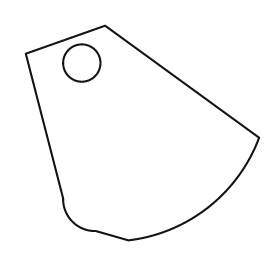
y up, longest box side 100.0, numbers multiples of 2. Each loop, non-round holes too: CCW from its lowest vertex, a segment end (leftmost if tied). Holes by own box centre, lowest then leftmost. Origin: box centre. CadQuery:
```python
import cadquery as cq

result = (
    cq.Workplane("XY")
    .moveTo(-6.0, -46.0)
    .threePointArc((28.0, -32.0), (50.0, -2.0))
    .lineTo(-16.0, 46.0)
    .lineTo(-50.0, 34.0)
    .lineTo(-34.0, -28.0)
    .threePointArc((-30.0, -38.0), (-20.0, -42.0))
    .close()
    .moveTo(-26.0, 30.0)
    .circle(8.0)
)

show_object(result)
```